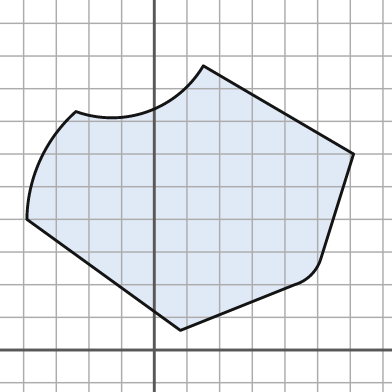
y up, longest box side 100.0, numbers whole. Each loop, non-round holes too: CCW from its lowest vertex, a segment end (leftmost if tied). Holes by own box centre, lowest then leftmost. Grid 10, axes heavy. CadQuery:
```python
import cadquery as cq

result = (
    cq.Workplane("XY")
    .moveTo(8.0, 6.0)
    .lineTo(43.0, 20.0)
    .threePointArc((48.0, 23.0), (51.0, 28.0))
    .lineTo(61.0, 60.0)
    .lineTo(15.0, 87.0)
    .threePointArc((-2.0, 73.0), (-24.0, 73.0))
    .threePointArc((-35.0, 58.0), (-39.0, 40.0))
    .close()
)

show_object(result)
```